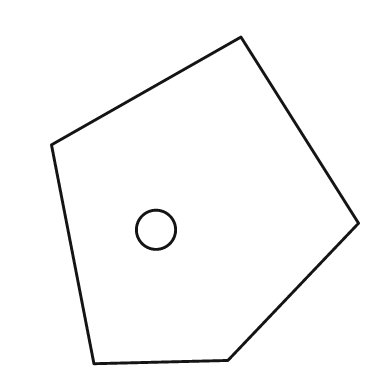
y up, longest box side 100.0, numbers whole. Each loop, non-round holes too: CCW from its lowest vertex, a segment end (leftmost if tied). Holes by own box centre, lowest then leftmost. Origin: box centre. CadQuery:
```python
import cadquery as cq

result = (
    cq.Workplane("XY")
    .moveTo(-34.0, -50.0)
    .lineTo(7.0, -49.0)
    .lineTo(47.0, -7.0)
    .lineTo(11.0, 50.0)
    .lineTo(-47.0, 17.0)
    .close()
    .moveTo(-15.0, -9.0)
    .circle(6.0)
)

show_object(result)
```